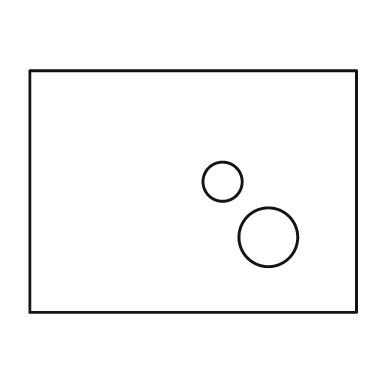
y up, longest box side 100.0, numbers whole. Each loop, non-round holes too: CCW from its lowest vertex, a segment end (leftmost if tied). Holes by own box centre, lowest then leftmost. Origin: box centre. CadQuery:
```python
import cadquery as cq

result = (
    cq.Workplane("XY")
    .moveTo(-50.0, -37.0)
    .lineTo(50.0, -37.0)
    .lineTo(50.0, 37.0)
    .lineTo(-50.0, 37.0)
    .close()
    .moveTo(23.0, -14.0)
    .circle(9.0)
    .moveTo(9.0, 3.0)
    .circle(6.0)
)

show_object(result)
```